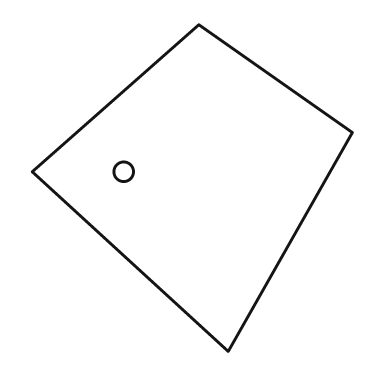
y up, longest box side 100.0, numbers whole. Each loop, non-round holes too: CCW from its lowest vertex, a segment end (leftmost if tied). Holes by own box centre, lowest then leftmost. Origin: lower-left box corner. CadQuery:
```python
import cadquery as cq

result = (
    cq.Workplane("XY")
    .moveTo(60.0, 0.0)
    .lineTo(98.0, 67.0)
    .lineTo(51.0, 100.0)
    .lineTo(0.0, 55.0)
    .close()
    .moveTo(28.0, 55.0)
    .circle(3.0)
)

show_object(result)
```